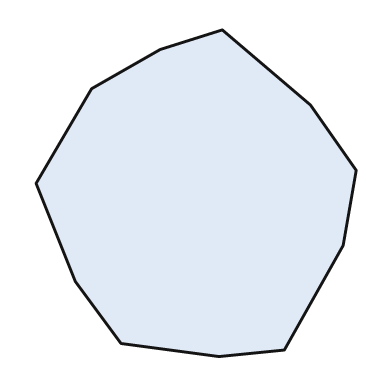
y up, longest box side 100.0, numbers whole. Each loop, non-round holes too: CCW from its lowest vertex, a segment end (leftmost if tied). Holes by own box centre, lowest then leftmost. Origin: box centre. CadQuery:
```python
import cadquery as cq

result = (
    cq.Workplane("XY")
    .moveTo(7.0, -50.0)
    .lineTo(27.0, -48.0)
    .lineTo(45.0, -16.0)
    .lineTo(49.0, 7.0)
    .lineTo(35.0, 27.0)
    .lineTo(8.0, 50.0)
    .lineTo(-11.0, 44.0)
    .lineTo(-32.0, 32.0)
    .lineTo(-49.0, 3.0)
    .lineTo(-37.0, -27.0)
    .lineTo(-23.0, -46.0)
    .close()
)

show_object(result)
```